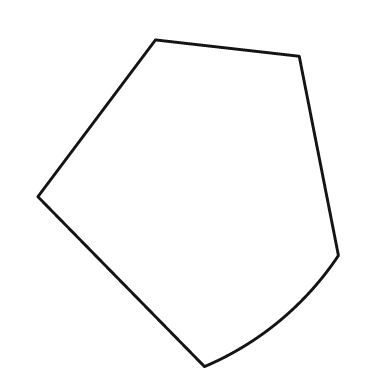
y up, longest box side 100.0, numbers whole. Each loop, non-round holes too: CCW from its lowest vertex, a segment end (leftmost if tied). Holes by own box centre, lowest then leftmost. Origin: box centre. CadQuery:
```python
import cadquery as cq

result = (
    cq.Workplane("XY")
    .moveTo(5.0, -50.0)
    .threePointArc((28.0, -36.0), (46.0, -16.0))
    .lineTo(34.0, 45.0)
    .lineTo(-10.0, 50.0)
    .lineTo(-46.0, 2.0)
    .close()
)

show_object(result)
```